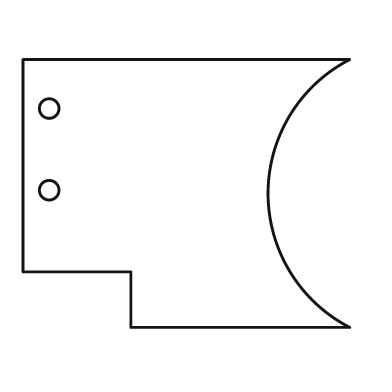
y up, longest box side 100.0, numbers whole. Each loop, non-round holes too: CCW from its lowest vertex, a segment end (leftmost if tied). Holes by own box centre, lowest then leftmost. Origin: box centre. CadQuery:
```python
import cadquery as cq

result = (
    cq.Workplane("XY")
    .moveTo(-17.0, -41.0)
    .lineTo(50.0, -41.0)
    .threePointArc((25.0, 0.0), (50.0, 41.0))
    .lineTo(-50.0, 41.0)
    .lineTo(-50.0, -24.0)
    .lineTo(-17.0, -24.0)
    .close()
    .moveTo(-42.0, 1.0)
    .circle(3.0)
    .moveTo(-42.0, 26.0)
    .circle(3.0)
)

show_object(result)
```